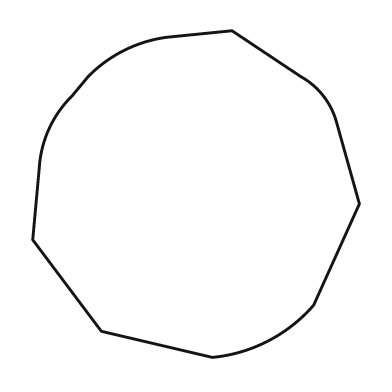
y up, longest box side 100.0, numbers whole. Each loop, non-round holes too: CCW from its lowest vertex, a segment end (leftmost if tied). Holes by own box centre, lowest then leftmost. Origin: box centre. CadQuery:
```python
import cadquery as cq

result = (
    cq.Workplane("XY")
    .moveTo(5.0, -50.0)
    .threePointArc((22.0, -45.0), (36.0, -34.0))
    .lineTo(50.0, -3.0)
    .lineTo(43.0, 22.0)
    .threePointArc((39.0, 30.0), (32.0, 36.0))
    .lineTo(11.0, 50.0)
    .lineTo(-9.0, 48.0)
    .threePointArc((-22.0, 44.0), (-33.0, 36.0))
    .lineTo(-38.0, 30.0)
    .threePointArc((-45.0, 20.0), (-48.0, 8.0))
    .lineTo(-50.0, -14.0)
    .lineTo(-29.0, -42.0)
    .close()
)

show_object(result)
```